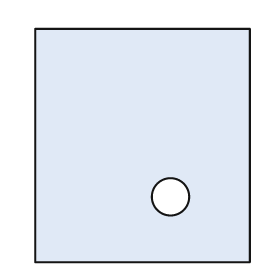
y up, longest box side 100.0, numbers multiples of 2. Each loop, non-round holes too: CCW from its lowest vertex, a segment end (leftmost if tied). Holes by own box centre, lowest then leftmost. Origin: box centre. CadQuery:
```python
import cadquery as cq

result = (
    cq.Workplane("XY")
    .moveTo(-46.0, -50.0)
    .lineTo(46.0, -50.0)
    .lineTo(46.0, 50.0)
    .lineTo(-46.0, 50.0)
    .close()
    .moveTo(12.0, -22.0)
    .circle(8.0)
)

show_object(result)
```